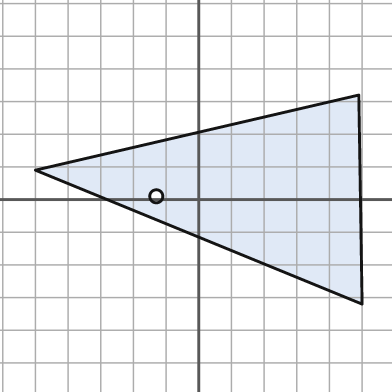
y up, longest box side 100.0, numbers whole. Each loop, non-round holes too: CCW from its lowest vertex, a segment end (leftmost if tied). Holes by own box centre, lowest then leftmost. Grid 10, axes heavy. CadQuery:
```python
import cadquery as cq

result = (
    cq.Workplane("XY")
    .moveTo(50.0, -32.0)
    .lineTo(49.0, 32.0)
    .lineTo(-50.0, 9.0)
    .close()
    .moveTo(-13.0, 1.0)
    .circle(2.0)
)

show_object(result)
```